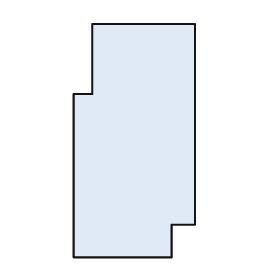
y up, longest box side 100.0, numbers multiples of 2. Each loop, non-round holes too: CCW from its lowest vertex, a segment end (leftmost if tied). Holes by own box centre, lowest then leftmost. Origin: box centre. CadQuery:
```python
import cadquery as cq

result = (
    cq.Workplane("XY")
    .moveTo(-26.0, -50.0)
    .lineTo(16.0, -50.0)
    .lineTo(16.0, -36.0)
    .lineTo(26.0, -36.0)
    .lineTo(26.0, 50.0)
    .lineTo(-18.0, 50.0)
    .lineTo(-18.0, 20.0)
    .lineTo(-26.0, 20.0)
    .close()
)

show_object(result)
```